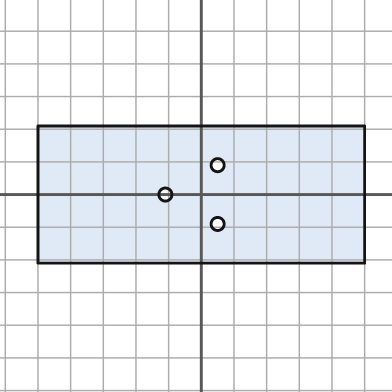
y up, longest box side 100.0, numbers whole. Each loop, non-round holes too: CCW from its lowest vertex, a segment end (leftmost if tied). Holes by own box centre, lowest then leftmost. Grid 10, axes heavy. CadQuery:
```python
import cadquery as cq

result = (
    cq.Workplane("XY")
    .moveTo(-50.0, -21.0)
    .lineTo(50.0, -21.0)
    .lineTo(50.0, 21.0)
    .lineTo(-50.0, 21.0)
    .close()
    .moveTo(5.0, -9.0)
    .circle(2.0)
    .moveTo(-11.0, 0.0)
    .circle(2.0)
    .moveTo(5.0, 9.0)
    .circle(2.0)
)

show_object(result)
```